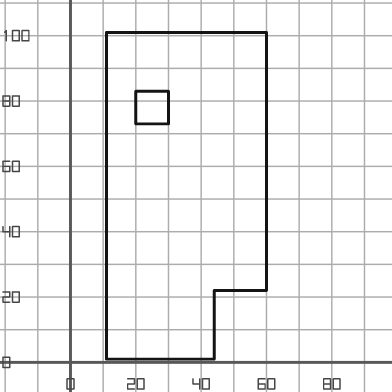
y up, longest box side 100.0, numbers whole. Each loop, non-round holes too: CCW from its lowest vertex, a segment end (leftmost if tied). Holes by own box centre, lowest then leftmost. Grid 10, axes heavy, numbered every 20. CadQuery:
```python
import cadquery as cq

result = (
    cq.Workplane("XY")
    .moveTo(11.0, 1.0)
    .lineTo(44.0, 1.0)
    .lineTo(44.0, 22.0)
    .lineTo(60.0, 22.0)
    .lineTo(60.0, 101.0)
    .lineTo(11.0, 101.0)
    .close()
    .moveTo(20.0, 73.0)
    .lineTo(30.0, 73.0)
    .lineTo(30.0, 83.0)
    .lineTo(20.0, 83.0)
    .close()
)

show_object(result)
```